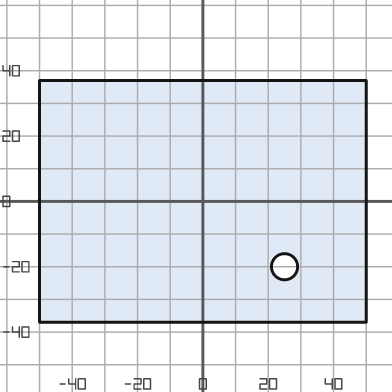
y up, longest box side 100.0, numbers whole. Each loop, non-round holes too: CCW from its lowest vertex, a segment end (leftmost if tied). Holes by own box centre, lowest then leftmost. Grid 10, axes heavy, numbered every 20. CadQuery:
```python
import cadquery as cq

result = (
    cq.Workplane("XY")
    .moveTo(-50.0, -37.0)
    .lineTo(50.0, -37.0)
    .lineTo(50.0, 37.0)
    .lineTo(-50.0, 37.0)
    .close()
    .moveTo(25.0, -20.0)
    .circle(4.0)
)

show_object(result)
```